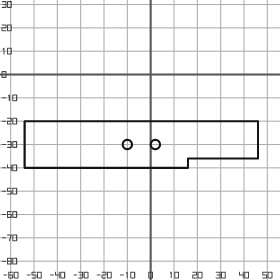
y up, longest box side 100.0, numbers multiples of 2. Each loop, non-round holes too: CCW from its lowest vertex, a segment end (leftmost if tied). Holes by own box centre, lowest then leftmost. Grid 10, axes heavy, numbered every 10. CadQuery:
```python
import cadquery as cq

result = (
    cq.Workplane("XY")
    .moveTo(-54.0, -40.0)
    .lineTo(16.0, -40.0)
    .lineTo(16.0, -36.0)
    .lineTo(46.0, -36.0)
    .lineTo(46.0, -20.0)
    .lineTo(-54.0, -20.0)
    .close()
    .moveTo(-10.0, -30.0)
    .circle(2.0)
    .moveTo(2.0, -30.0)
    .circle(2.0)
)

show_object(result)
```